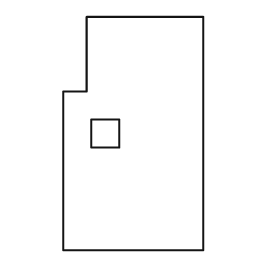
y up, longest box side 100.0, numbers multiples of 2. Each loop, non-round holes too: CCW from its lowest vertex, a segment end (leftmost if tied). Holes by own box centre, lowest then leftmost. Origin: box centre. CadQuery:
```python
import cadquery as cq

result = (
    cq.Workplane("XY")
    .moveTo(-30.0, -50.0)
    .lineTo(30.0, -50.0)
    .lineTo(30.0, 50.0)
    .lineTo(-20.0, 50.0)
    .lineTo(-20.0, 18.0)
    .lineTo(-30.0, 18.0)
    .close()
    .moveTo(-18.0, -6.0)
    .lineTo(-6.0, -6.0)
    .lineTo(-6.0, 6.0)
    .lineTo(-18.0, 6.0)
    .close()
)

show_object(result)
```